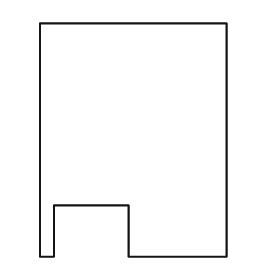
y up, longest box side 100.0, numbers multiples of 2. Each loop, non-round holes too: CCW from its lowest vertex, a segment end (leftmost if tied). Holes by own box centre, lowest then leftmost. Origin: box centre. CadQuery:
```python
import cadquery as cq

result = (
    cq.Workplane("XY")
    .moveTo(-40.0, -50.0)
    .lineTo(-34.0, -50.0)
    .lineTo(-34.0, -28.0)
    .lineTo(-2.0, -28.0)
    .lineTo(-2.0, -50.0)
    .lineTo(40.0, -50.0)
    .lineTo(40.0, 50.0)
    .lineTo(-40.0, 50.0)
    .close()
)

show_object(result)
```